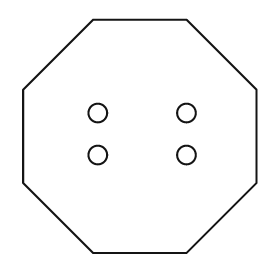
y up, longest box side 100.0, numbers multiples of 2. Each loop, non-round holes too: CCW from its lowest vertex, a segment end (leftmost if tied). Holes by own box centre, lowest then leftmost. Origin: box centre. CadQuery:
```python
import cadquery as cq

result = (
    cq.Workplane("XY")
    .moveTo(-20.0, -50.0)
    .lineTo(20.0, -50.0)
    .lineTo(50.0, -20.0)
    .lineTo(50.0, 20.0)
    .lineTo(20.0, 50.0)
    .lineTo(-20.0, 50.0)
    .lineTo(-50.0, 20.0)
    .lineTo(-50.0, -20.0)
    .close()
    .moveTo(-18.0, -8.0)
    .circle(4.0)
    .moveTo(20.0, -8.0)
    .circle(4.0)
    .moveTo(-18.0, 10.0)
    .circle(4.0)
    .moveTo(20.0, 10.0)
    .circle(4.0)
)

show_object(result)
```